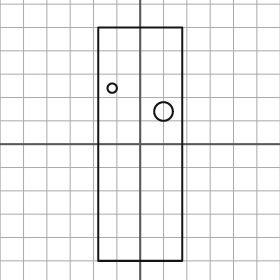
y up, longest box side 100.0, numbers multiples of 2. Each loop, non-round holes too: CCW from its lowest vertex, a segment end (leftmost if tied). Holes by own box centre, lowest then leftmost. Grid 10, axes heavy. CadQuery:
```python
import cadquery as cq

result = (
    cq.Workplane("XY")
    .moveTo(-18.0, -50.0)
    .lineTo(18.0, -50.0)
    .lineTo(18.0, 50.0)
    .lineTo(-18.0, 50.0)
    .close()
    .moveTo(10.0, 14.0)
    .circle(4.0)
    .moveTo(-12.0, 24.0)
    .circle(2.0)
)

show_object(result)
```